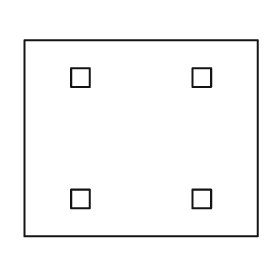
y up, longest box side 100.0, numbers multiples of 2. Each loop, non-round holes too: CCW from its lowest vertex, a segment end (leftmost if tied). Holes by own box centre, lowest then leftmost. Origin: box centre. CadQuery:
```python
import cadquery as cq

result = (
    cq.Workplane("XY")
    .moveTo(-50.0, -42.0)
    .lineTo(50.0, -42.0)
    .lineTo(50.0, 42.0)
    .lineTo(-50.0, 42.0)
    .close()
    .moveTo(-30.0, -30.0)
    .lineTo(-22.0, -30.0)
    .lineTo(-22.0, -22.0)
    .lineTo(-30.0, -22.0)
    .close()
    .moveTo(22.0, -30.0)
    .lineTo(30.0, -30.0)
    .lineTo(30.0, -22.0)
    .lineTo(22.0, -22.0)
    .close()
    .moveTo(-30.0, 22.0)
    .lineTo(-22.0, 22.0)
    .lineTo(-22.0, 30.0)
    .lineTo(-30.0, 30.0)
    .close()
    .moveTo(22.0, 22.0)
    .lineTo(30.0, 22.0)
    .lineTo(30.0, 30.0)
    .lineTo(22.0, 30.0)
    .close()
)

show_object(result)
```